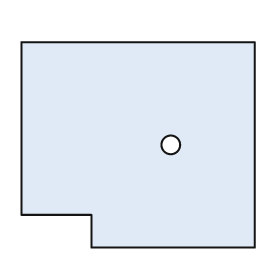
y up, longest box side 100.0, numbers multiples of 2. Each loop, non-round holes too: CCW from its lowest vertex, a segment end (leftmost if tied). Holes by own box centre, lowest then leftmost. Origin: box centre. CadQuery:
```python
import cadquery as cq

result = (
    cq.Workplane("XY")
    .moveTo(-20.0, -44.0)
    .lineTo(50.0, -44.0)
    .lineTo(50.0, 44.0)
    .lineTo(-50.0, 44.0)
    .lineTo(-50.0, -30.0)
    .lineTo(-20.0, -30.0)
    .close()
    .moveTo(14.0, 0.0)
    .circle(4.0)
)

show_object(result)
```